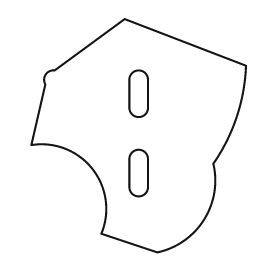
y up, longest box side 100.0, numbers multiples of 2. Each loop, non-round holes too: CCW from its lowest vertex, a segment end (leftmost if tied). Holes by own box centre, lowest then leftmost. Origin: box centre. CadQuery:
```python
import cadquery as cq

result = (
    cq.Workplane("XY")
    .moveTo(8.0, -50.0)
    .threePointArc((28.0, -36.0), (32.0, -12.0))
    .threePointArc((42.0, 8.0), (46.0, 30.0))
    .lineTo(-6.0, 50.0)
    .lineTo(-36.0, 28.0)
    .threePointArc((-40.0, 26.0), (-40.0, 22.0))
    .lineTo(-46.0, -4.0)
    .threePointArc((-20.0, -14.0), (-16.0, -42.0))
    .close()
    .moveTo(-4.0, -22.0)
    .threePointArc((0.0, -26.0), (4.0, -22.0))
    .lineTo(4.0, -10.0)
    .threePointArc((0.0, -6.0), (-4.0, -10.0))
    .close()
    .moveTo(-4.0, 12.0)
    .threePointArc((0.0, 8.0), (4.0, 12.0))
    .lineTo(4.0, 24.0)
    .threePointArc((0.0, 28.0), (-4.0, 24.0))
    .close()
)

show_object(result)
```